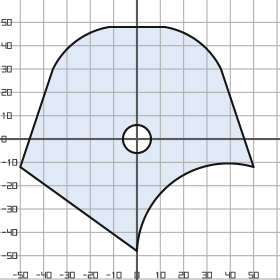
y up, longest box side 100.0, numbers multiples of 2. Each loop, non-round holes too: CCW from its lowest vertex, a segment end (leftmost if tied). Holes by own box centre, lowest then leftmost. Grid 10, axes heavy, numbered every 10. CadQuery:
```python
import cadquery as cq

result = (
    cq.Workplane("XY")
    .moveTo(0.0, -48.0)
    .threePointArc((16.0, -18.0), (50.0, -12.0))
    .lineTo(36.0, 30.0)
    .threePointArc((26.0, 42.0), (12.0, 48.0))
    .lineTo(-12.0, 48.0)
    .threePointArc((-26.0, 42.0), (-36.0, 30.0))
    .lineTo(-50.0, -12.0)
    .close()
    .moveTo(0.0, 0.0)
    .circle(6.0)
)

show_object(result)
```